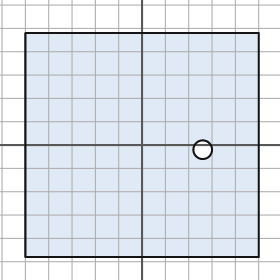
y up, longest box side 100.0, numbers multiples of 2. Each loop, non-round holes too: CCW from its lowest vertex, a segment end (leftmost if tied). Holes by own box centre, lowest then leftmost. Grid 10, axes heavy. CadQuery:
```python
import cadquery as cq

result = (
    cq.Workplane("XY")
    .moveTo(-50.0, -48.0)
    .lineTo(50.0, -48.0)
    .lineTo(50.0, 48.0)
    .lineTo(-50.0, 48.0)
    .close()
    .moveTo(26.0, -2.0)
    .circle(4.0)
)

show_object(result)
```